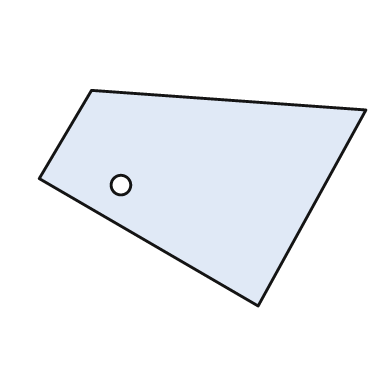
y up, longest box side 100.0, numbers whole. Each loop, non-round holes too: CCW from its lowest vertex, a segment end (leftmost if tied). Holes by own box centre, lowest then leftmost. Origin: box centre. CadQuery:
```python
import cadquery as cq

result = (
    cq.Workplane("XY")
    .moveTo(17.0, -33.0)
    .lineTo(50.0, 27.0)
    .lineTo(-34.0, 33.0)
    .lineTo(-50.0, 6.0)
    .close()
    .moveTo(-25.0, 4.0)
    .circle(3.0)
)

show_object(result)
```